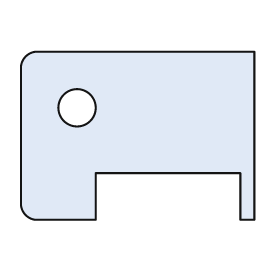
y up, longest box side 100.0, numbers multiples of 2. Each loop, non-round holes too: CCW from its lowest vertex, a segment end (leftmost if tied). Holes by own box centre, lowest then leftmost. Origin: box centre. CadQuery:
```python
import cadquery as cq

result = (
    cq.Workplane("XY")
    .moveTo(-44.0, -36.0)
    .lineTo(-18.0, -36.0)
    .lineTo(-18.0, -16.0)
    .lineTo(44.0, -16.0)
    .lineTo(44.0, -36.0)
    .lineTo(50.0, -36.0)
    .lineTo(50.0, 36.0)
    .lineTo(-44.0, 36.0)
    .threePointArc((-48.0, 34.0), (-50.0, 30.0))
    .lineTo(-50.0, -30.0)
    .threePointArc((-48.0, -34.0), (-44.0, -36.0))
    .close()
    .moveTo(-26.0, 12.0)
    .circle(8.0)
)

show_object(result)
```